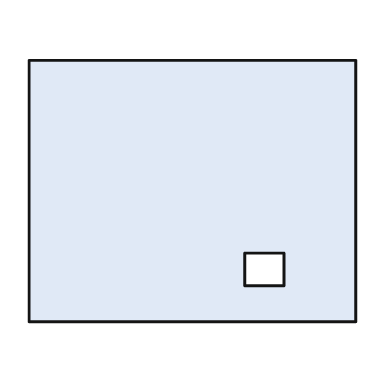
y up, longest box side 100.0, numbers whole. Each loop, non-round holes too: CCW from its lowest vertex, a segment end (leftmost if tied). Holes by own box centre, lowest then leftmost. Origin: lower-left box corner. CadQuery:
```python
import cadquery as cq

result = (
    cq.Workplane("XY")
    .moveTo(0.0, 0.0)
    .lineTo(100.0, 0.0)
    .lineTo(100.0, 80.0)
    .lineTo(0.0, 80.0)
    .close()
    .moveTo(66.0, 11.0)
    .lineTo(78.0, 11.0)
    .lineTo(78.0, 21.0)
    .lineTo(66.0, 21.0)
    .close()
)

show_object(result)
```